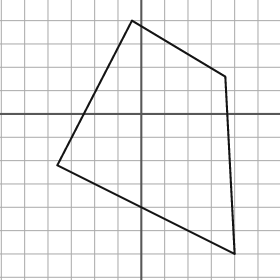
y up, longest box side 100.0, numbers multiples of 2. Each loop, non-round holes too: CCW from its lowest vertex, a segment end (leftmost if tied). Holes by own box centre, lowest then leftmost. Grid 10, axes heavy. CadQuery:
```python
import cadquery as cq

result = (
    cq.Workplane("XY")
    .moveTo(40.0, -60.0)
    .lineTo(36.0, 16.0)
    .lineTo(-4.0, 40.0)
    .lineTo(-36.0, -22.0)
    .close()
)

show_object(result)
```